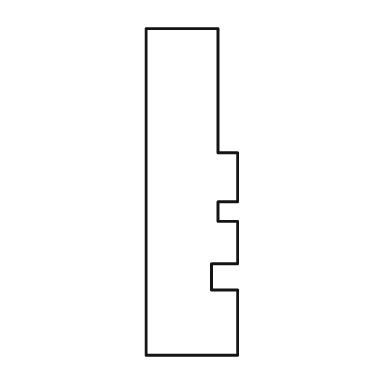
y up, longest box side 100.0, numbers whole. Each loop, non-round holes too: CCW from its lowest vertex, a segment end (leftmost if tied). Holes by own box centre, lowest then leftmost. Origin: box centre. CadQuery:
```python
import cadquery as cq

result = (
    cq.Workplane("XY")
    .moveTo(-14.0, -50.0)
    .lineTo(14.0, -50.0)
    .lineTo(14.0, -30.0)
    .lineTo(6.0, -30.0)
    .lineTo(6.0, -22.0)
    .lineTo(14.0, -22.0)
    .lineTo(14.0, -9.0)
    .lineTo(8.0, -9.0)
    .lineTo(8.0, -3.0)
    .lineTo(14.0, -3.0)
    .lineTo(14.0, 12.0)
    .lineTo(8.0, 12.0)
    .lineTo(8.0, 50.0)
    .lineTo(-14.0, 50.0)
    .close()
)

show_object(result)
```